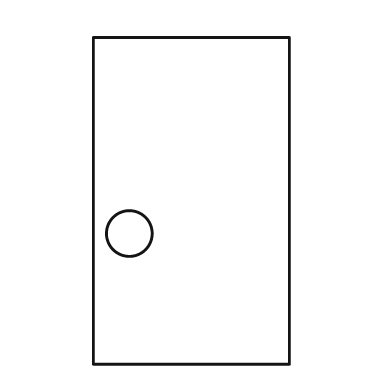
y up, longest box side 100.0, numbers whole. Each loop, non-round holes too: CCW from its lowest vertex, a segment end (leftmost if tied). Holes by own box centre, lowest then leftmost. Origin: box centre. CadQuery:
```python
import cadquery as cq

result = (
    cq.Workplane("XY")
    .moveTo(-30.0, -50.0)
    .lineTo(30.0, -50.0)
    .lineTo(30.0, 50.0)
    .lineTo(-30.0, 50.0)
    .close()
    .moveTo(-19.0, -10.0)
    .circle(7.0)
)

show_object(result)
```